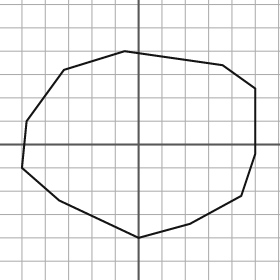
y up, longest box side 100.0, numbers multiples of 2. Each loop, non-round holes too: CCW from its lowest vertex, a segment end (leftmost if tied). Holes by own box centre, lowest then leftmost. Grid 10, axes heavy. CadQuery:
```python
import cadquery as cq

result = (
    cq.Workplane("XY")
    .moveTo(0.0, -40.0)
    .lineTo(22.0, -34.0)
    .lineTo(44.0, -22.0)
    .lineTo(50.0, -4.0)
    .lineTo(50.0, 24.0)
    .lineTo(36.0, 34.0)
    .lineTo(-6.0, 40.0)
    .lineTo(-32.0, 32.0)
    .lineTo(-48.0, 10.0)
    .lineTo(-50.0, -10.0)
    .lineTo(-34.0, -24.0)
    .close()
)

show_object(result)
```